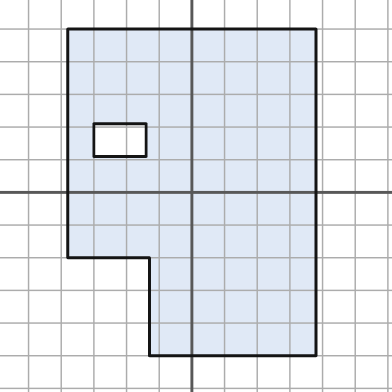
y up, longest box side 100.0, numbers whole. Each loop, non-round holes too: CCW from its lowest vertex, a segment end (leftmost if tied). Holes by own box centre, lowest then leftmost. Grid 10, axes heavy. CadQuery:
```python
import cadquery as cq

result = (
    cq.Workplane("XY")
    .moveTo(-13.0, -50.0)
    .lineTo(38.0, -50.0)
    .lineTo(38.0, 50.0)
    .lineTo(-38.0, 50.0)
    .lineTo(-38.0, -20.0)
    .lineTo(-13.0, -20.0)
    .close()
    .moveTo(-30.0, 11.0)
    .lineTo(-14.0, 11.0)
    .lineTo(-14.0, 21.0)
    .lineTo(-30.0, 21.0)
    .close()
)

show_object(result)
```